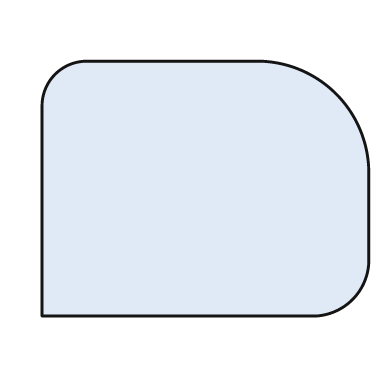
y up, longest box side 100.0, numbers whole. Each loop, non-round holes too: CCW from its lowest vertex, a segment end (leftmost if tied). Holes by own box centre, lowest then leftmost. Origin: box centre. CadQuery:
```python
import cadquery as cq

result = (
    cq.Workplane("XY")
    .moveTo(-50.0, -39.0)
    .lineTo(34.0, -39.0)
    .threePointArc((45.0, -34.0), (50.0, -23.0))
    .lineTo(50.0, 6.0)
    .threePointArc((40.0, 29.0), (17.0, 39.0))
    .lineTo(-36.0, 39.0)
    .threePointArc((-46.0, 35.0), (-50.0, 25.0))
    .close()
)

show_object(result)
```